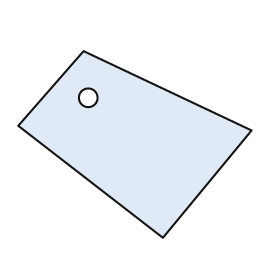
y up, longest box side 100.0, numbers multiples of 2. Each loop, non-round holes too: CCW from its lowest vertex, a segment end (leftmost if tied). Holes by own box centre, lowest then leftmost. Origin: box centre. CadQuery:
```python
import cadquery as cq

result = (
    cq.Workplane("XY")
    .moveTo(12.0, -40.0)
    .lineTo(50.0, 6.0)
    .lineTo(-22.0, 40.0)
    .lineTo(-50.0, 8.0)
    .close()
    .moveTo(-20.0, 20.0)
    .circle(4.0)
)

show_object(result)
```